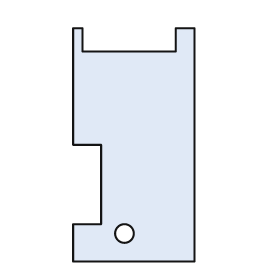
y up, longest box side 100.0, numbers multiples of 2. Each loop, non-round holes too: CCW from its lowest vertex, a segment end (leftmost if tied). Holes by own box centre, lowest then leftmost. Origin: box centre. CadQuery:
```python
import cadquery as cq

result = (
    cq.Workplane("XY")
    .moveTo(-26.0, -50.0)
    .lineTo(26.0, -50.0)
    .lineTo(26.0, 50.0)
    .lineTo(18.0, 50.0)
    .lineTo(18.0, 40.0)
    .lineTo(-22.0, 40.0)
    .lineTo(-22.0, 50.0)
    .lineTo(-26.0, 50.0)
    .lineTo(-26.0, 0.0)
    .lineTo(-14.0, 0.0)
    .lineTo(-14.0, -34.0)
    .lineTo(-26.0, -34.0)
    .close()
    .moveTo(-4.0, -38.0)
    .circle(4.0)
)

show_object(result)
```